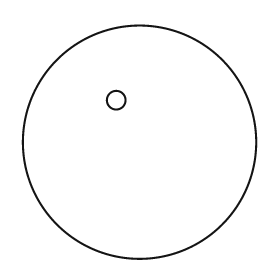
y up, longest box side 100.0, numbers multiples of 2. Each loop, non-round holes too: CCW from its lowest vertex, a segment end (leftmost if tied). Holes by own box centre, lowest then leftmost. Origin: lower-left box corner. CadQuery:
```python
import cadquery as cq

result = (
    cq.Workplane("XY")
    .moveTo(50.0, 50.0)
    .circle(50.0)
    .moveTo(40.0, 68.0)
    .circle(4.0)
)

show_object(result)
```